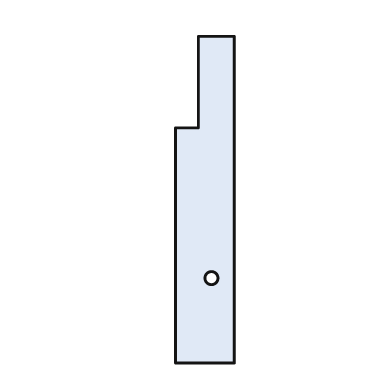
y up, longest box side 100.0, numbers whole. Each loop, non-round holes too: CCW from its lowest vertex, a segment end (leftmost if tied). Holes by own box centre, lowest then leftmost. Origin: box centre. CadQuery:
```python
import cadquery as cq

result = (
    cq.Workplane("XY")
    .moveTo(-9.0, -50.0)
    .lineTo(9.0, -50.0)
    .lineTo(9.0, 50.0)
    .lineTo(-2.0, 50.0)
    .lineTo(-2.0, 22.0)
    .lineTo(-9.0, 22.0)
    .close()
    .moveTo(2.0, -24.0)
    .circle(2.0)
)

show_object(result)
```